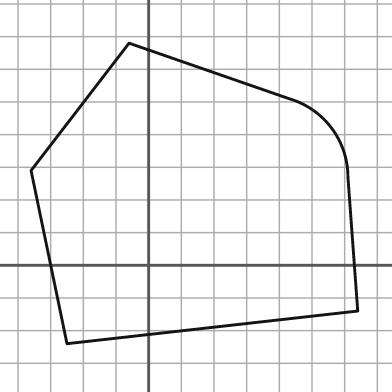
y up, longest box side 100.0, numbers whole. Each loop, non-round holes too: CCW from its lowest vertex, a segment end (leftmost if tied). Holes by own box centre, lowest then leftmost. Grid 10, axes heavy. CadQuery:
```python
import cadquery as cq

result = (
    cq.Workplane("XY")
    .moveTo(-25.0, -24.0)
    .lineTo(64.0, -14.0)
    .lineTo(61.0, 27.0)
    .threePointArc((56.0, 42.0), (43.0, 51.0))
    .lineTo(-6.0, 68.0)
    .lineTo(-36.0, 29.0)
    .close()
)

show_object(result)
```